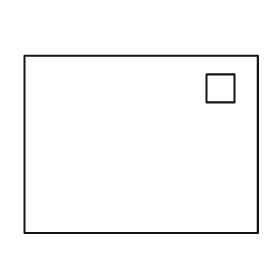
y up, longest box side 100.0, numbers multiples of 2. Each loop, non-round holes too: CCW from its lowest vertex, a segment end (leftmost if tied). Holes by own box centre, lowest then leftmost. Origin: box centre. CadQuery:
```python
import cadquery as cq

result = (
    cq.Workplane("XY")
    .moveTo(-50.0, -38.0)
    .lineTo(50.0, -38.0)
    .lineTo(50.0, 38.0)
    .lineTo(-50.0, 38.0)
    .close()
    .moveTo(28.0, 18.0)
    .lineTo(40.0, 18.0)
    .lineTo(40.0, 30.0)
    .lineTo(28.0, 30.0)
    .close()
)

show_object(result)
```